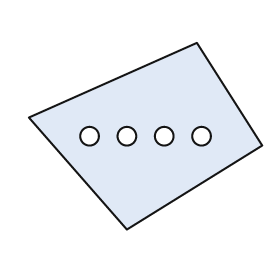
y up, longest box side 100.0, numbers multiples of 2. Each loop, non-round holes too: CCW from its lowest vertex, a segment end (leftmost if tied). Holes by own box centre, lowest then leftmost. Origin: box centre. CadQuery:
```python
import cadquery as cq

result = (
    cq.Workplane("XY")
    .moveTo(-8.0, -40.0)
    .lineTo(50.0, -4.0)
    .lineTo(22.0, 40.0)
    .lineTo(-50.0, 8.0)
    .close()
    .moveTo(-24.0, 0.0)
    .circle(4.0)
    .moveTo(-8.0, 0.0)
    .circle(4.0)
    .moveTo(8.0, 0.0)
    .circle(4.0)
    .moveTo(24.0, 0.0)
    .circle(4.0)
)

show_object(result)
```